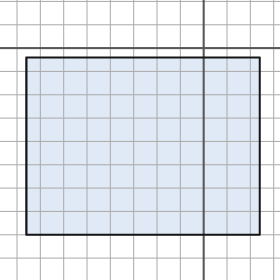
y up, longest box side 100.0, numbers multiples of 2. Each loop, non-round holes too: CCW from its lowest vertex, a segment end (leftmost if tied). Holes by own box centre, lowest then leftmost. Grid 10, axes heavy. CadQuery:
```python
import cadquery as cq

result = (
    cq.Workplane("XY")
    .moveTo(-76.0, -80.0)
    .lineTo(24.0, -80.0)
    .lineTo(24.0, -4.0)
    .lineTo(-76.0, -4.0)
    .close()
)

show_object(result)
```